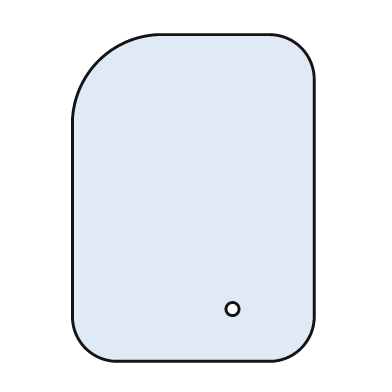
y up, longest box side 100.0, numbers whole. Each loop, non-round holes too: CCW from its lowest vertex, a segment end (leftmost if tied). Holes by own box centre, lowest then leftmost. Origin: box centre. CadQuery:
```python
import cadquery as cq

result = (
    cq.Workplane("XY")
    .moveTo(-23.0, -50.0)
    .lineTo(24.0, -50.0)
    .threePointArc((33.0, -46.0), (37.0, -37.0))
    .lineTo(37.0, 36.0)
    .threePointArc((33.0, 46.0), (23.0, 50.0))
    .lineTo(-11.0, 50.0)
    .threePointArc((-29.0, 42.0), (-37.0, 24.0))
    .lineTo(-37.0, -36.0)
    .threePointArc((-33.0, -46.0), (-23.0, -50.0))
    .close()
    .moveTo(12.0, -34.0)
    .circle(2.0)
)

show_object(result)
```